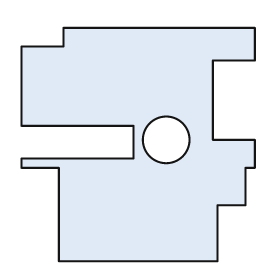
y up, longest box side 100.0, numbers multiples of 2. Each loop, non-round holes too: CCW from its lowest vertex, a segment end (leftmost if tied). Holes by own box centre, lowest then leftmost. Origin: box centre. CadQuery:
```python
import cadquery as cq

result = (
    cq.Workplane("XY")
    .moveTo(-34.0, -50.0)
    .lineTo(34.0, -50.0)
    .lineTo(34.0, -26.0)
    .lineTo(46.0, -26.0)
    .lineTo(46.0, -10.0)
    .lineTo(50.0, -10.0)
    .lineTo(50.0, 2.0)
    .lineTo(32.0, 2.0)
    .lineTo(32.0, 36.0)
    .lineTo(50.0, 36.0)
    .lineTo(50.0, 50.0)
    .lineTo(-32.0, 50.0)
    .lineTo(-32.0, 42.0)
    .lineTo(-50.0, 42.0)
    .lineTo(-50.0, 8.0)
    .lineTo(-2.0, 8.0)
    .lineTo(-2.0, -6.0)
    .lineTo(-50.0, -6.0)
    .lineTo(-50.0, -10.0)
    .lineTo(-34.0, -10.0)
    .close()
    .moveTo(12.0, 2.0)
    .circle(10.0)
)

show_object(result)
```